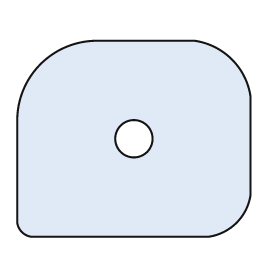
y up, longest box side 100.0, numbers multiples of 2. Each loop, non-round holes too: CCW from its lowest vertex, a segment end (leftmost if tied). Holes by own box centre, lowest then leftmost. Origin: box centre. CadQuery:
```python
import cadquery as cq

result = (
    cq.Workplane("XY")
    .moveTo(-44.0, -42.0)
    .lineTo(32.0, -42.0)
    .threePointArc((44.0, -36.0), (50.0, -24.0))
    .lineTo(50.0, 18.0)
    .threePointArc((42.0, 34.0), (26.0, 42.0))
    .lineTo(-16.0, 42.0)
    .threePointArc((-40.0, 32.0), (-50.0, 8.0))
    .lineTo(-50.0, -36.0)
    .threePointArc((-48.0, -40.0), (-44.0, -42.0))
    .close()
    .moveTo(0.0, 0.0)
    .circle(8.0)
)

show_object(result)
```